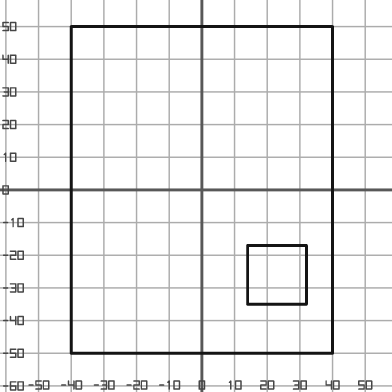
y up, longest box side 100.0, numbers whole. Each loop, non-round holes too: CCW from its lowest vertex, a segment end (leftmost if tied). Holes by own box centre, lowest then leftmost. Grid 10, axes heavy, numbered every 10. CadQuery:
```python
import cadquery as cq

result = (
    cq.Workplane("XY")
    .moveTo(-40.0, -50.0)
    .lineTo(40.0, -50.0)
    .lineTo(40.0, 50.0)
    .lineTo(-40.0, 50.0)
    .close()
    .moveTo(14.0, -35.0)
    .lineTo(32.0, -35.0)
    .lineTo(32.0, -17.0)
    .lineTo(14.0, -17.0)
    .close()
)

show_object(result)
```